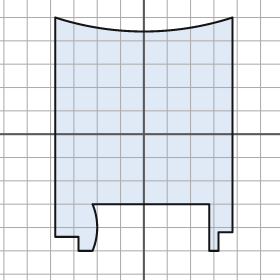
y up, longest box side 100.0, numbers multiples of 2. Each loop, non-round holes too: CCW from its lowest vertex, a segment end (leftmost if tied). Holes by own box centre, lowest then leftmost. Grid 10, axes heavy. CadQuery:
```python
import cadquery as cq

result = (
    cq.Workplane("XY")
    .moveTo(-28.0, -50.0)
    .lineTo(-22.0, -50.0)
    .threePointArc((-20.0, -40.0), (-22.0, -30.0))
    .lineTo(28.0, -30.0)
    .lineTo(28.0, -50.0)
    .lineTo(32.0, -50.0)
    .lineTo(32.0, -42.0)
    .lineTo(38.0, -42.0)
    .lineTo(38.0, 50.0)
    .threePointArc((0.0, 44.0), (-38.0, 50.0))
    .lineTo(-38.0, -44.0)
    .lineTo(-28.0, -44.0)
    .close()
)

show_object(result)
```